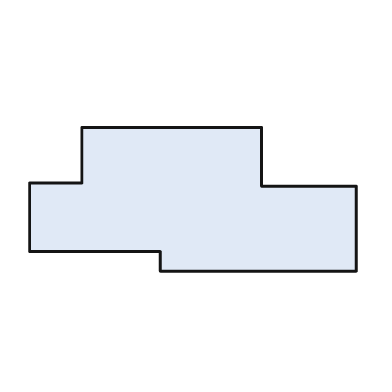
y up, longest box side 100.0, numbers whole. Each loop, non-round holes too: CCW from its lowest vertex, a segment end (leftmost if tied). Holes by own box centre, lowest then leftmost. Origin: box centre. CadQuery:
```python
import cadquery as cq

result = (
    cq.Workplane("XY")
    .moveTo(-10.0, -22.0)
    .lineTo(50.0, -22.0)
    .lineTo(50.0, 4.0)
    .lineTo(21.0, 4.0)
    .lineTo(21.0, 22.0)
    .lineTo(-34.0, 22.0)
    .lineTo(-34.0, 5.0)
    .lineTo(-50.0, 5.0)
    .lineTo(-50.0, -16.0)
    .lineTo(-10.0, -16.0)
    .close()
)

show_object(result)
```